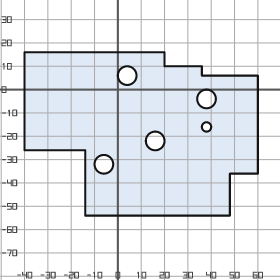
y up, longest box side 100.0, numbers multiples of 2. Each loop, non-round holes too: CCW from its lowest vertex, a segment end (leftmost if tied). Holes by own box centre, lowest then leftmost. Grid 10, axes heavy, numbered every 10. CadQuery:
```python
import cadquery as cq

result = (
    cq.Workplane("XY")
    .moveTo(-14.0, -54.0)
    .lineTo(48.0, -54.0)
    .lineTo(48.0, -36.0)
    .lineTo(60.0, -36.0)
    .lineTo(60.0, 6.0)
    .lineTo(36.0, 6.0)
    .lineTo(36.0, 10.0)
    .lineTo(20.0, 10.0)
    .lineTo(20.0, 16.0)
    .lineTo(-40.0, 16.0)
    .lineTo(-40.0, -26.0)
    .lineTo(-14.0, -26.0)
    .close()
    .moveTo(-6.0, -32.0)
    .circle(4.0)
    .moveTo(16.0, -22.0)
    .circle(4.0)
    .moveTo(38.0, -16.0)
    .circle(2.0)
    .moveTo(38.0, -4.0)
    .circle(4.0)
    .moveTo(4.0, 6.0)
    .circle(4.0)
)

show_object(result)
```